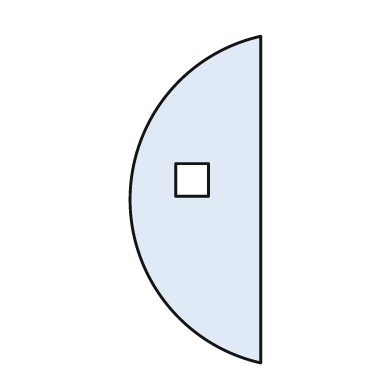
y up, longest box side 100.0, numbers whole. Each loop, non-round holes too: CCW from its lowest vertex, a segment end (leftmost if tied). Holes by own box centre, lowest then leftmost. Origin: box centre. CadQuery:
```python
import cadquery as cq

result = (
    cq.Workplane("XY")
    .moveTo(20.0, -50.0)
    .lineTo(20.0, 50.0)
    .threePointArc((-20.0, 0.0), (20.0, -50.0))
    .close()
    .moveTo(-6.0, 1.0)
    .lineTo(4.0, 1.0)
    .lineTo(4.0, 11.0)
    .lineTo(-6.0, 11.0)
    .close()
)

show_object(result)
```